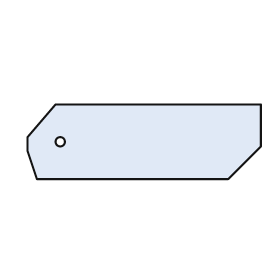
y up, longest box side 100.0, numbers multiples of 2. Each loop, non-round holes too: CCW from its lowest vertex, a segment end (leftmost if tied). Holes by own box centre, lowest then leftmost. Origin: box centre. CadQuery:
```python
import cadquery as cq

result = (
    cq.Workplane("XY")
    .moveTo(-46.0, -16.0)
    .lineTo(36.0, -16.0)
    .lineTo(50.0, -2.0)
    .lineTo(50.0, 16.0)
    .lineTo(-38.0, 16.0)
    .lineTo(-50.0, 2.0)
    .lineTo(-50.0, -4.0)
    .close()
    .moveTo(-36.0, 0.0)
    .circle(2.0)
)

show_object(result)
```